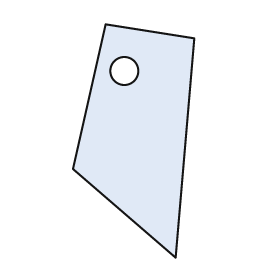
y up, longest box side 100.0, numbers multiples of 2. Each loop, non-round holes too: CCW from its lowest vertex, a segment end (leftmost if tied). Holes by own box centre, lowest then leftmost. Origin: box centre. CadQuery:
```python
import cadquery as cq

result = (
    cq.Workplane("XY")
    .moveTo(18.0, -50.0)
    .lineTo(26.0, 44.0)
    .lineTo(-12.0, 50.0)
    .lineTo(-26.0, -12.0)
    .close()
    .moveTo(-4.0, 30.0)
    .circle(6.0)
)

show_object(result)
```